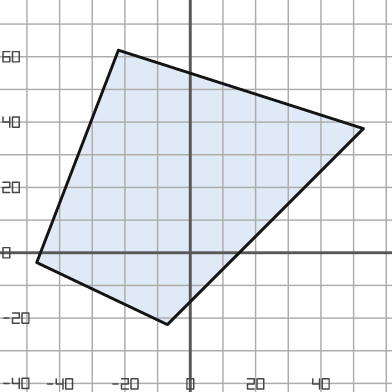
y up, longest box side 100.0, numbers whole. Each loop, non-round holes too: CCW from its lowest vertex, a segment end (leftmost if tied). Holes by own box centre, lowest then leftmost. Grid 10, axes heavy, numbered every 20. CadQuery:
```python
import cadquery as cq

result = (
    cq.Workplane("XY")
    .moveTo(-7.0, -22.0)
    .lineTo(53.0, 38.0)
    .lineTo(-22.0, 62.0)
    .lineTo(-47.0, -3.0)
    .close()
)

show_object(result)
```